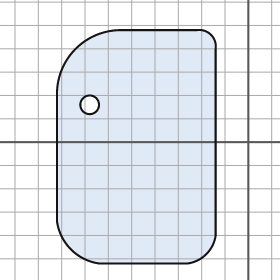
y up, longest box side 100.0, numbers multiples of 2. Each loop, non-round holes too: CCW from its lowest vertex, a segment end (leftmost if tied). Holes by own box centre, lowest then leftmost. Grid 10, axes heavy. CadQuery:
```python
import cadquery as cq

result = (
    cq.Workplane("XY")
    .moveTo(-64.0, -52.0)
    .lineTo(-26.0, -52.0)
    .threePointArc((-18.0, -48.0), (-14.0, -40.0))
    .lineTo(-14.0, 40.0)
    .threePointArc((-16.0, 46.0), (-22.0, 48.0))
    .lineTo(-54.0, 48.0)
    .threePointArc((-74.0, 40.0), (-82.0, 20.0))
    .lineTo(-82.0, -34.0)
    .threePointArc((-76.0, -46.0), (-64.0, -52.0))
    .close()
    .moveTo(-68.0, 16.0)
    .circle(4.0)
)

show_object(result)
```